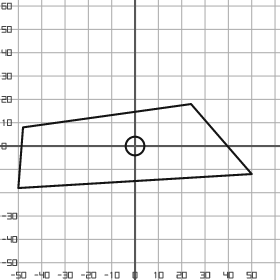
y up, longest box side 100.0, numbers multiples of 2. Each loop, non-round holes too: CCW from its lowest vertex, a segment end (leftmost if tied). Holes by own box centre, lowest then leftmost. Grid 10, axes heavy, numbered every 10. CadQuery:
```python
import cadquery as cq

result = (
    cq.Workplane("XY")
    .moveTo(-50.0, -18.0)
    .lineTo(50.0, -12.0)
    .lineTo(24.0, 18.0)
    .lineTo(-48.0, 8.0)
    .close()
    .moveTo(0.0, 0.0)
    .circle(4.0)
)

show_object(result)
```